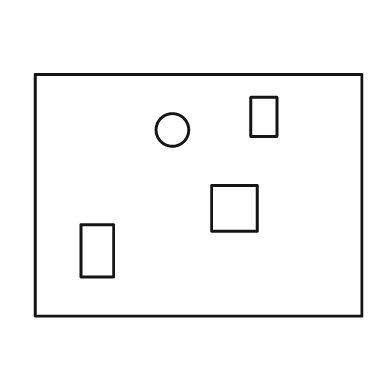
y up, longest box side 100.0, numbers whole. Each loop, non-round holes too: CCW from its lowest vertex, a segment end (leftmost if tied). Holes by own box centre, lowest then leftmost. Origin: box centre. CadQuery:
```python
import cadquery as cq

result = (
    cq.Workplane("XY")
    .moveTo(-50.0, -37.0)
    .lineTo(50.0, -37.0)
    .lineTo(50.0, 37.0)
    .lineTo(-50.0, 37.0)
    .close()
    .moveTo(-36.0, -25.0)
    .lineTo(-26.0, -25.0)
    .lineTo(-26.0, -9.0)
    .lineTo(-36.0, -9.0)
    .close()
    .moveTo(4.0, -11.0)
    .lineTo(18.0, -11.0)
    .lineTo(18.0, 3.0)
    .lineTo(4.0, 3.0)
    .close()
    .moveTo(-8.0, 20.0)
    .circle(5.0)
    .moveTo(16.0, 18.0)
    .lineTo(24.0, 18.0)
    .lineTo(24.0, 30.0)
    .lineTo(16.0, 30.0)
    .close()
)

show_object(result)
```